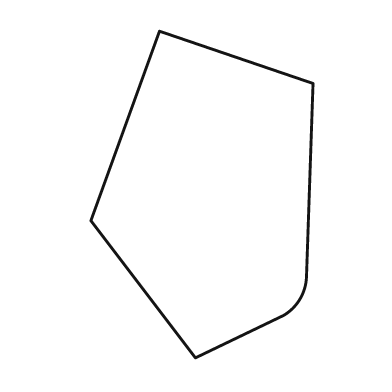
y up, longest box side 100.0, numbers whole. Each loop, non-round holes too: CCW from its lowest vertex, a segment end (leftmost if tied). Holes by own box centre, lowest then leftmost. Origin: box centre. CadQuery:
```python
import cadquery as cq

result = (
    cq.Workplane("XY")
    .moveTo(-2.0, -50.0)
    .lineTo(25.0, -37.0)
    .threePointArc((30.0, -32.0), (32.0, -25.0))
    .lineTo(34.0, 34.0)
    .lineTo(-13.0, 50.0)
    .lineTo(-34.0, -8.0)
    .close()
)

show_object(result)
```